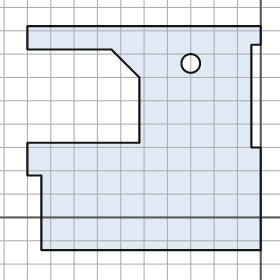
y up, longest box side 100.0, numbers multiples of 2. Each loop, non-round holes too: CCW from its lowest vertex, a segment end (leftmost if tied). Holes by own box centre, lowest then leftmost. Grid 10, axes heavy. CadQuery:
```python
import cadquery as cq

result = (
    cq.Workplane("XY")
    .moveTo(-94.0, -14.0)
    .lineTo(0.0, -14.0)
    .lineTo(0.0, 30.0)
    .lineTo(-4.0, 30.0)
    .lineTo(-4.0, 74.0)
    .lineTo(0.0, 74.0)
    .lineTo(0.0, 82.0)
    .lineTo(-100.0, 82.0)
    .lineTo(-100.0, 72.0)
    .lineTo(-64.0, 72.0)
    .lineTo(-52.0, 60.0)
    .lineTo(-52.0, 32.0)
    .lineTo(-100.0, 32.0)
    .lineTo(-100.0, 18.0)
    .lineTo(-94.0, 18.0)
    .close()
    .moveTo(-30.0, 66.0)
    .circle(4.0)
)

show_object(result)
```